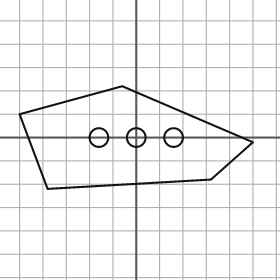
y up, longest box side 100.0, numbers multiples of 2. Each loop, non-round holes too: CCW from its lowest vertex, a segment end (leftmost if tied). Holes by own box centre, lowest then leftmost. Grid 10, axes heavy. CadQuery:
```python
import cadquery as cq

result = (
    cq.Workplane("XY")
    .moveTo(-38.0, -22.0)
    .lineTo(32.0, -18.0)
    .lineTo(50.0, -2.0)
    .lineTo(-6.0, 22.0)
    .lineTo(-50.0, 10.0)
    .close()
    .moveTo(-16.0, 0.0)
    .circle(4.0)
    .moveTo(0.0, 0.0)
    .circle(4.0)
    .moveTo(16.0, 0.0)
    .circle(4.0)
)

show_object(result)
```